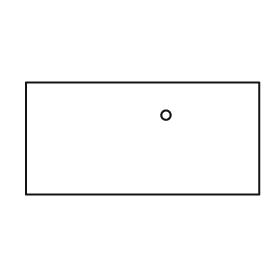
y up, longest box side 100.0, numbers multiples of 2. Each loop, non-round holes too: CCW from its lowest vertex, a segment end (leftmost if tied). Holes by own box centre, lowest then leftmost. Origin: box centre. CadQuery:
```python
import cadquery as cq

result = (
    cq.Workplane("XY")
    .moveTo(-50.0, -24.0)
    .lineTo(50.0, -24.0)
    .lineTo(50.0, 24.0)
    .lineTo(-50.0, 24.0)
    .close()
    .moveTo(10.0, 10.0)
    .circle(2.0)
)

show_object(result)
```